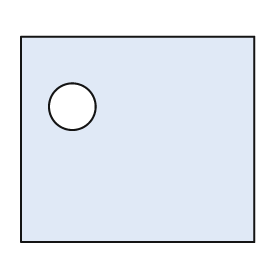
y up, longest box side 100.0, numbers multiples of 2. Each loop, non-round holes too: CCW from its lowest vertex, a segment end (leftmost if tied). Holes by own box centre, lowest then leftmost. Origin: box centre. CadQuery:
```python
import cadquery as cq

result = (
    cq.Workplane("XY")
    .moveTo(-50.0, -44.0)
    .lineTo(50.0, -44.0)
    .lineTo(50.0, 44.0)
    .lineTo(-50.0, 44.0)
    .close()
    .moveTo(-28.0, 14.0)
    .circle(10.0)
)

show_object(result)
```